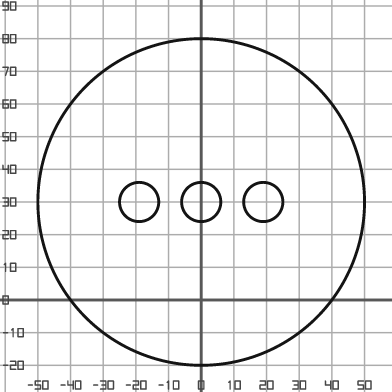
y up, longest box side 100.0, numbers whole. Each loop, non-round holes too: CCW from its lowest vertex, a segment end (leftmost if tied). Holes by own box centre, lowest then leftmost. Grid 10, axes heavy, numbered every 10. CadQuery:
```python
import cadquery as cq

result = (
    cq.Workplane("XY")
    .moveTo(0.0, 30.0)
    .circle(50.0)
    .moveTo(-19.0, 30.0)
    .circle(6.0)
    .moveTo(0.0, 30.0)
    .circle(6.0)
    .moveTo(19.0, 30.0)
    .circle(6.0)
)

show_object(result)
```